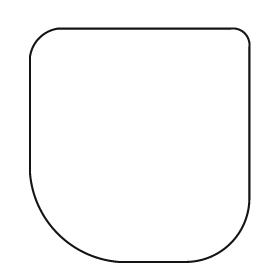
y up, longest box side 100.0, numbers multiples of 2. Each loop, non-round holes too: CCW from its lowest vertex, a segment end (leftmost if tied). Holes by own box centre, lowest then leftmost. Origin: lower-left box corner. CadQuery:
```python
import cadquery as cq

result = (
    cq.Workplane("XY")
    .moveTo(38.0, 0.0)
    .lineTo(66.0, 0.0)
    .threePointArc((86.0, 8.0), (94.0, 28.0))
    .lineTo(94.0, 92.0)
    .threePointArc((92.0, 98.0), (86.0, 100.0))
    .lineTo(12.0, 100.0)
    .threePointArc((4.0, 96.0), (0.0, 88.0))
    .lineTo(0.0, 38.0)
    .threePointArc((12.0, 12.0), (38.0, 0.0))
    .close()
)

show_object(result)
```